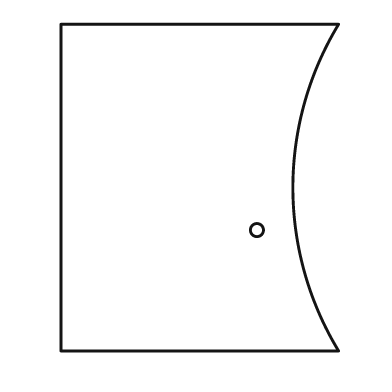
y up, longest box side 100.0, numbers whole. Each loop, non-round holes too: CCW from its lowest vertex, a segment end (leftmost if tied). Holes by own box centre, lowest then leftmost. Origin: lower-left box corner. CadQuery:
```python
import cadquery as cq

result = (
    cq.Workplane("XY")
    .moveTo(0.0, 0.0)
    .lineTo(85.0, 0.0)
    .threePointArc((71.0, 50.0), (85.0, 100.0))
    .lineTo(0.0, 100.0)
    .close()
    .moveTo(60.0, 37.0)
    .circle(2.0)
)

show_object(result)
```